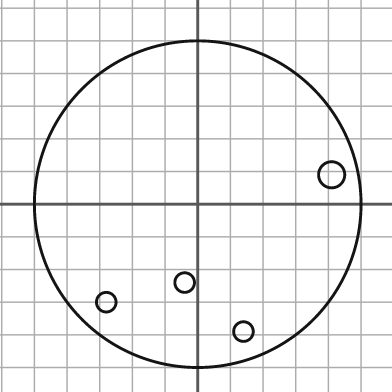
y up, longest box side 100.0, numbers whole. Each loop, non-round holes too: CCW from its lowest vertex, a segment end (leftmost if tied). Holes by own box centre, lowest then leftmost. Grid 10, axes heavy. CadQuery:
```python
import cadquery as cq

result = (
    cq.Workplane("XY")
    .moveTo(0.0, 0.0)
    .circle(50.0)
    .moveTo(14.0, -39.0)
    .circle(3.0)
    .moveTo(-28.0, -30.0)
    .circle(3.0)
    .moveTo(-4.0, -24.0)
    .circle(3.0)
    .moveTo(41.0, 9.0)
    .circle(4.0)
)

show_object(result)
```